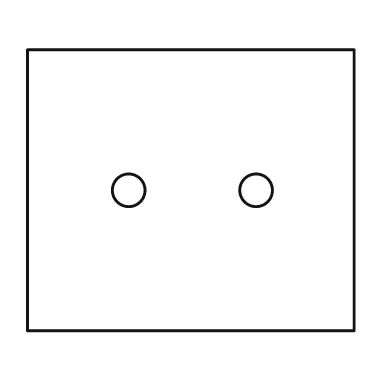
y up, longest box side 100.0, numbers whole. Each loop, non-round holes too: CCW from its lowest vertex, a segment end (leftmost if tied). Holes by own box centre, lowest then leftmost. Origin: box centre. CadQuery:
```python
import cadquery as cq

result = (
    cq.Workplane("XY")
    .moveTo(-50.0, -43.0)
    .lineTo(50.0, -43.0)
    .lineTo(50.0, 43.0)
    .lineTo(-50.0, 43.0)
    .close()
    .moveTo(-19.0, 0.0)
    .circle(5.0)
    .moveTo(20.0, 0.0)
    .circle(5.0)
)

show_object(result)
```